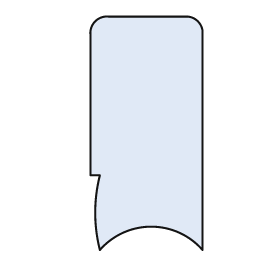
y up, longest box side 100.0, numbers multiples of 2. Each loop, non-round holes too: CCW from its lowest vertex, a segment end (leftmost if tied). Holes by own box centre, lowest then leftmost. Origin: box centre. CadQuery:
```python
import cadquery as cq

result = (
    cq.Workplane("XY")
    .moveTo(-20.0, -50.0)
    .threePointArc((2.0, -40.0), (24.0, -50.0))
    .lineTo(24.0, 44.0)
    .threePointArc((22.0, 48.0), (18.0, 50.0))
    .lineTo(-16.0, 50.0)
    .threePointArc((-22.0, 48.0), (-24.0, 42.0))
    .lineTo(-24.0, -18.0)
    .lineTo(-20.0, -18.0)
    .threePointArc((-22.0, -34.0), (-20.0, -50.0))
    .close()
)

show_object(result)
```